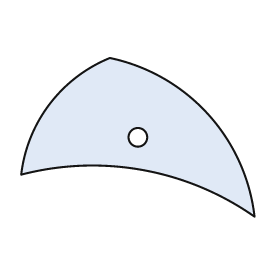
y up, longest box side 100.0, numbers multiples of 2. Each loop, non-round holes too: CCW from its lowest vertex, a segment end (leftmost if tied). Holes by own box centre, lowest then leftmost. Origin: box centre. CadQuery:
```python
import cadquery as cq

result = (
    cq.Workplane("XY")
    .moveTo(50.0, -34.0)
    .threePointArc((30.0, 10.0), (-12.0, 34.0))
    .threePointArc((-38.0, 14.0), (-50.0, -16.0))
    .threePointArc((2.0, -14.0), (50.0, -34.0))
    .close()
    .moveTo(0.0, 0.0)
    .circle(4.0)
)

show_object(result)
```